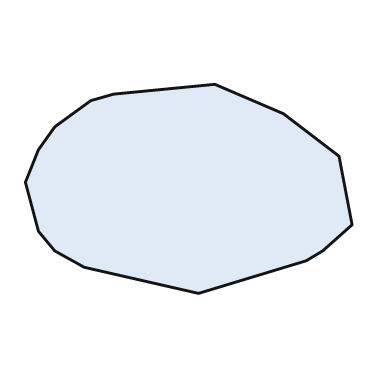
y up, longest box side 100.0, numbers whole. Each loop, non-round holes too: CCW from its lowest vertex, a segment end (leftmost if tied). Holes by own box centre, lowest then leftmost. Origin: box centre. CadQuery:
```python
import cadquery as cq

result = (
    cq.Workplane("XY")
    .moveTo(3.0, -32.0)
    .lineTo(36.0, -22.0)
    .lineTo(41.0, -19.0)
    .lineTo(50.0, -11.0)
    .lineTo(46.0, 10.0)
    .lineTo(29.0, 23.0)
    .lineTo(8.0, 32.0)
    .lineTo(-23.0, 29.0)
    .lineTo(-30.0, 27.0)
    .lineTo(-41.0, 19.0)
    .lineTo(-46.0, 12.0)
    .lineTo(-50.0, 2.0)
    .lineTo(-46.0, -13.0)
    .lineTo(-41.0, -19.0)
    .lineTo(-32.0, -24.0)
    .close()
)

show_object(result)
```